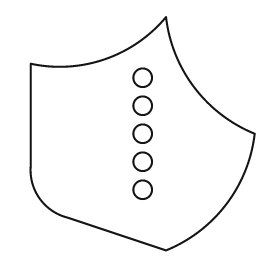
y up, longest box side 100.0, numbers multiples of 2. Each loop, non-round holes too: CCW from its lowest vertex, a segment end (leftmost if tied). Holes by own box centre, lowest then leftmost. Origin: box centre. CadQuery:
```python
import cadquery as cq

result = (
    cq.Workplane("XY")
    .moveTo(10.0, -50.0)
    .threePointArc((36.0, -30.0), (48.0, 0.0))
    .threePointArc((22.0, 20.0), (10.0, 50.0))
    .threePointArc((-16.0, 32.0), (-48.0, 30.0))
    .lineTo(-48.0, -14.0)
    .threePointArc((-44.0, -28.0), (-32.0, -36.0))
    .close()
    .moveTo(0.0, -24.0)
    .circle(4.0)
    .moveTo(0.0, -12.0)
    .circle(4.0)
    .moveTo(0.0, 0.0)
    .circle(4.0)
    .moveTo(0.0, 12.0)
    .circle(4.0)
    .moveTo(0.0, 24.0)
    .circle(4.0)
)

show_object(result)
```